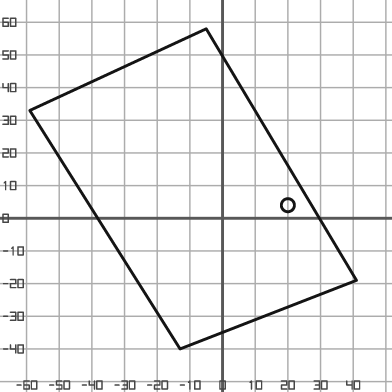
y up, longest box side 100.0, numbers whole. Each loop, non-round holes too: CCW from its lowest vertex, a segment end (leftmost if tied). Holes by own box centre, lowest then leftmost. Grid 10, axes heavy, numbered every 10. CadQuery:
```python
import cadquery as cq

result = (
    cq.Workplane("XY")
    .moveTo(-13.0, -40.0)
    .lineTo(41.0, -19.0)
    .lineTo(-5.0, 58.0)
    .lineTo(-59.0, 33.0)
    .close()
    .moveTo(20.0, 4.0)
    .circle(2.0)
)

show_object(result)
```